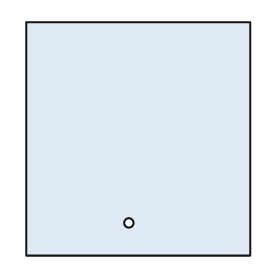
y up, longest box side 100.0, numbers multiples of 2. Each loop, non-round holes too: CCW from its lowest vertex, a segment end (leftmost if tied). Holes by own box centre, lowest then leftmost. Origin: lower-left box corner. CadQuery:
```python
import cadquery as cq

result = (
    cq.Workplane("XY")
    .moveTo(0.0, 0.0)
    .lineTo(96.0, 0.0)
    .lineTo(96.0, 100.0)
    .lineTo(0.0, 100.0)
    .close()
    .moveTo(44.0, 14.0)
    .circle(2.0)
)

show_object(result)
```